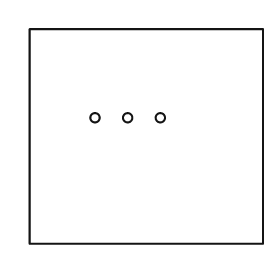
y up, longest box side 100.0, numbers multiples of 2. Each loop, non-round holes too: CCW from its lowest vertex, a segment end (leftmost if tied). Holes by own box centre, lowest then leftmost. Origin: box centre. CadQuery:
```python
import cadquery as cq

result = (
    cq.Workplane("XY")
    .moveTo(-50.0, -46.0)
    .lineTo(50.0, -46.0)
    .lineTo(50.0, 46.0)
    .lineTo(-50.0, 46.0)
    .close()
    .moveTo(-22.0, 8.0)
    .circle(2.0)
    .moveTo(-8.0, 8.0)
    .circle(2.0)
    .moveTo(6.0, 8.0)
    .circle(2.0)
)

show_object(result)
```